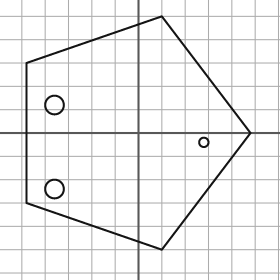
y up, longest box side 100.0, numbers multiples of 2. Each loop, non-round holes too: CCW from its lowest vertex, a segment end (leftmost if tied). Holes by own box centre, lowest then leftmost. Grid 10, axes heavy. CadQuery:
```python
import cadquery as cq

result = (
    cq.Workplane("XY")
    .moveTo(10.0, -50.0)
    .lineTo(48.0, 0.0)
    .lineTo(10.0, 50.0)
    .lineTo(-48.0, 30.0)
    .lineTo(-48.0, -30.0)
    .close()
    .moveTo(-36.0, -24.0)
    .circle(4.0)
    .moveTo(28.0, -4.0)
    .circle(2.0)
    .moveTo(-36.0, 12.0)
    .circle(4.0)
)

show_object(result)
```